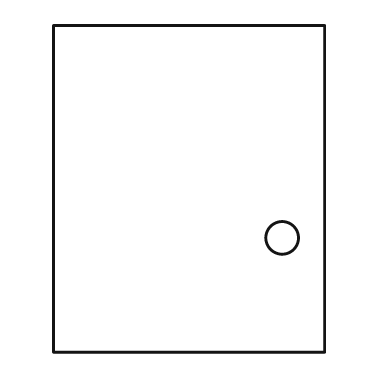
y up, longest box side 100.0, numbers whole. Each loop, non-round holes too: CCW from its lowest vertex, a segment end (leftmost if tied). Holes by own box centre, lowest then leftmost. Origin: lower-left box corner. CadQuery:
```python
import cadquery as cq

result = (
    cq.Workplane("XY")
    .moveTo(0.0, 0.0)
    .lineTo(83.0, 0.0)
    .lineTo(83.0, 100.0)
    .lineTo(0.0, 100.0)
    .close()
    .moveTo(70.0, 35.0)
    .circle(5.0)
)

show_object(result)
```